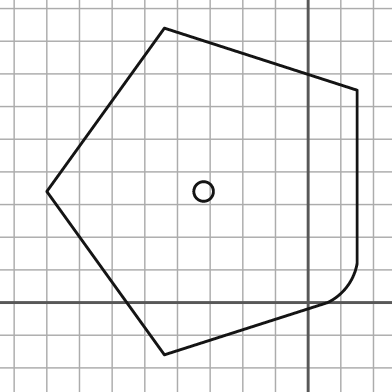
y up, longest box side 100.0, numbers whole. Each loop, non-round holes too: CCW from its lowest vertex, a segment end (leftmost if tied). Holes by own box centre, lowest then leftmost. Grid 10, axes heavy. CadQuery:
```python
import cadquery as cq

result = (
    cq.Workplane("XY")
    .moveTo(-44.0, -16.0)
    .lineTo(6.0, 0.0)
    .threePointArc((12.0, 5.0), (15.0, 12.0))
    .lineTo(15.0, 65.0)
    .lineTo(-44.0, 84.0)
    .lineTo(-80.0, 34.0)
    .close()
    .moveTo(-32.0, 34.0)
    .circle(3.0)
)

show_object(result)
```